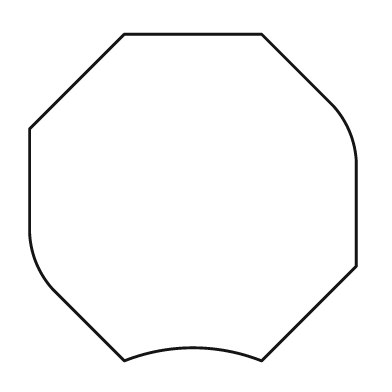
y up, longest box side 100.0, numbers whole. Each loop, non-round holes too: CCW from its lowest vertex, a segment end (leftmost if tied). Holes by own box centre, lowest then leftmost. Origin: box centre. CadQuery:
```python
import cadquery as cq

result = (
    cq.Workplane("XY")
    .moveTo(-21.0, -50.0)
    .threePointArc((0.0, -46.0), (21.0, -50.0))
    .lineTo(50.0, -21.0)
    .lineTo(50.0, 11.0)
    .threePointArc((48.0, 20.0), (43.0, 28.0))
    .lineTo(21.0, 50.0)
    .lineTo(-21.0, 50.0)
    .lineTo(-50.0, 21.0)
    .lineTo(-50.0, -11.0)
    .threePointArc((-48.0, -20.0), (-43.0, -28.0))
    .close()
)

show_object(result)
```